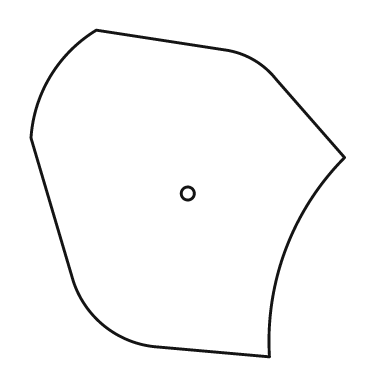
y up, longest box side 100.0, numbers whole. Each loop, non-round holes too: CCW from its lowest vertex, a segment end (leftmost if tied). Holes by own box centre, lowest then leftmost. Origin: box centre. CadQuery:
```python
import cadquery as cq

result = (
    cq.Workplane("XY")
    .moveTo(25.0, -50.0)
    .threePointArc((30.0, -17.0), (48.0, 11.0))
    .lineTo(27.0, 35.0)
    .threePointArc((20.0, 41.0), (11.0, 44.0))
    .lineTo(-28.0, 50.0)
    .threePointArc((-42.0, 36.0), (-48.0, 17.0))
    .lineTo(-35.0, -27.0)
    .threePointArc((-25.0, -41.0), (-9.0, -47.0))
    .close()
    .moveTo(0.0, 0.0)
    .circle(2.0)
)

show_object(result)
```